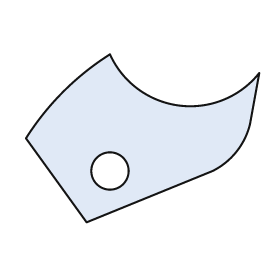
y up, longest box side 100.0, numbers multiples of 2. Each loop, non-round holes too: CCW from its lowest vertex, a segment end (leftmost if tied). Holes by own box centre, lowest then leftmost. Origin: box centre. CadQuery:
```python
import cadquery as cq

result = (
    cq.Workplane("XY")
    .moveTo(-24.0, -36.0)
    .lineTo(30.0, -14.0)
    .threePointArc((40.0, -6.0), (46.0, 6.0))
    .lineTo(50.0, 28.0)
    .threePointArc((16.0, 14.0), (-14.0, 36.0))
    .threePointArc((-34.0, 20.0), (-50.0, 0.0))
    .close()
    .moveTo(-14.0, -14.0)
    .circle(8.0)
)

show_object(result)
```